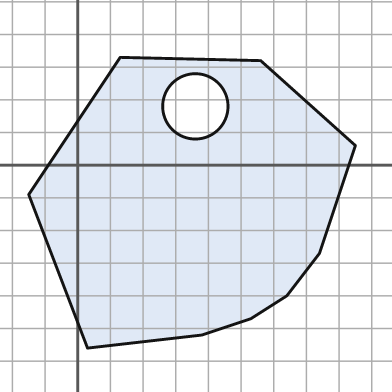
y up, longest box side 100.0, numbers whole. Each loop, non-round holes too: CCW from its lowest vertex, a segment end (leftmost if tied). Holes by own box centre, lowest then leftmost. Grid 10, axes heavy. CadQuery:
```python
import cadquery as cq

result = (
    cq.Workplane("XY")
    .moveTo(3.0, -56.0)
    .lineTo(38.0, -52.0)
    .lineTo(53.0, -47.0)
    .lineTo(64.0, -40.0)
    .lineTo(74.0, -27.0)
    .lineTo(85.0, 6.0)
    .lineTo(56.0, 32.0)
    .lineTo(13.0, 33.0)
    .lineTo(-15.0, -9.0)
    .close()
    .moveTo(36.0, 18.0)
    .circle(10.0)
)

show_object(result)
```